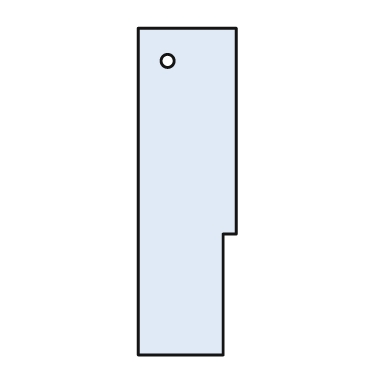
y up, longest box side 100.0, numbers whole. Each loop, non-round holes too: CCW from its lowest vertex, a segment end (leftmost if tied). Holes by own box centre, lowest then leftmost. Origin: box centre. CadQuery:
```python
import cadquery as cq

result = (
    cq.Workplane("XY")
    .moveTo(-15.0, -50.0)
    .lineTo(11.0, -50.0)
    .lineTo(11.0, -13.0)
    .lineTo(15.0, -13.0)
    .lineTo(15.0, 50.0)
    .lineTo(-15.0, 50.0)
    .close()
    .moveTo(-6.0, 40.0)
    .circle(2.0)
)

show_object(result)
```